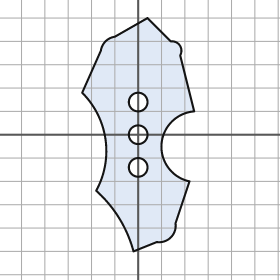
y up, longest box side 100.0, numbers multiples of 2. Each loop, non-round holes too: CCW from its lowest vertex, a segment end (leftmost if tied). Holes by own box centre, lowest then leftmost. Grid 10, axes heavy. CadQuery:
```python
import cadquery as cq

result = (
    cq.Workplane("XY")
    .moveTo(-2.0, -50.0)
    .lineTo(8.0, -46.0)
    .threePointArc((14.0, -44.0), (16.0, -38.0))
    .lineTo(22.0, -20.0)
    .threePointArc((10.0, -4.0), (24.0, 10.0))
    .lineTo(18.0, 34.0)
    .threePointArc((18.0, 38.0), (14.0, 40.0))
    .lineTo(4.0, 50.0)
    .lineTo(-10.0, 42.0)
    .threePointArc((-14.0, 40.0), (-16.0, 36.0))
    .lineTo(-24.0, 18.0)
    .threePointArc((-14.0, -2.0), (-18.0, -24.0))
    .threePointArc((-8.0, -36.0), (-2.0, -50.0))
    .close()
    .moveTo(0.0, -14.0)
    .circle(4.0)
    .moveTo(0.0, 0.0)
    .circle(4.0)
    .moveTo(0.0, 14.0)
    .circle(4.0)
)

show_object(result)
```